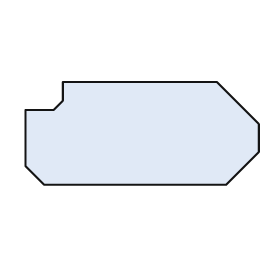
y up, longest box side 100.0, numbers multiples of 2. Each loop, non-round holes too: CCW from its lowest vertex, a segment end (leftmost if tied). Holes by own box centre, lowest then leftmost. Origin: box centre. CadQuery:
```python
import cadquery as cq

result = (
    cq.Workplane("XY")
    .moveTo(-42.0, -22.0)
    .lineTo(36.0, -22.0)
    .lineTo(50.0, -8.0)
    .lineTo(50.0, 4.0)
    .lineTo(32.0, 22.0)
    .lineTo(-34.0, 22.0)
    .lineTo(-34.0, 14.0)
    .lineTo(-38.0, 10.0)
    .lineTo(-50.0, 10.0)
    .lineTo(-50.0, -14.0)
    .close()
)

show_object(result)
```